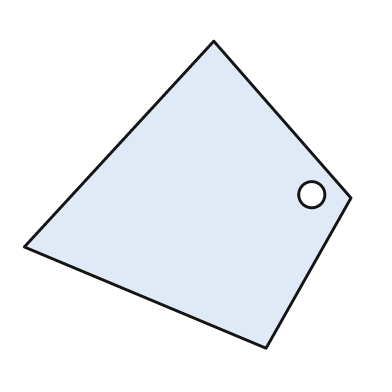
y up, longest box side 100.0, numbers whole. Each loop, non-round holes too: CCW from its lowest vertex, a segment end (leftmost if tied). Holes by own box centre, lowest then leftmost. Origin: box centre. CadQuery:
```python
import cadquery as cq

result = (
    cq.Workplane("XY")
    .moveTo(24.0, -47.0)
    .lineTo(50.0, -1.0)
    .lineTo(8.0, 47.0)
    .lineTo(-50.0, -16.0)
    .close()
    .moveTo(38.0, 0.0)
    .circle(4.0)
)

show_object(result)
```